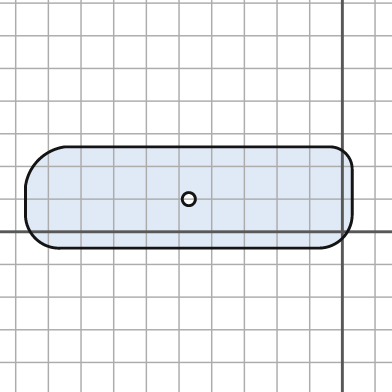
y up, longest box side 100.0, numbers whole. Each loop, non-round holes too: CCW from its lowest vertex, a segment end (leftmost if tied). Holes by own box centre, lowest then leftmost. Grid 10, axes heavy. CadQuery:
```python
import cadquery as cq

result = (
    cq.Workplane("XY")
    .moveTo(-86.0, -5.0)
    .lineTo(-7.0, -5.0)
    .threePointArc((0.0, -2.0), (3.0, 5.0))
    .lineTo(3.0, 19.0)
    .threePointArc((1.0, 24.0), (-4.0, 26.0))
    .lineTo(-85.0, 26.0)
    .threePointArc((-93.0, 22.0), (-97.0, 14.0))
    .lineTo(-97.0, 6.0)
    .threePointArc((-94.0, -2.0), (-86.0, -5.0))
    .close()
    .moveTo(-47.0, 10.0)
    .circle(2.0)
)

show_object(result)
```